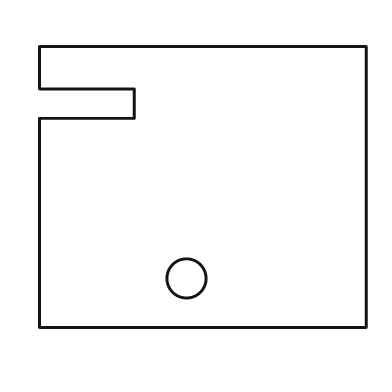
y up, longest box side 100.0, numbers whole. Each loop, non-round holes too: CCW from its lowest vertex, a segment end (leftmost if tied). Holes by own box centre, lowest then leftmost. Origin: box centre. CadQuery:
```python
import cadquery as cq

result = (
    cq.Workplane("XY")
    .moveTo(-50.0, -43.0)
    .lineTo(50.0, -43.0)
    .lineTo(50.0, 43.0)
    .lineTo(-50.0, 43.0)
    .lineTo(-50.0, 30.0)
    .lineTo(-21.0, 30.0)
    .lineTo(-21.0, 21.0)
    .lineTo(-50.0, 21.0)
    .close()
    .moveTo(-5.0, -28.0)
    .circle(6.0)
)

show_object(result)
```